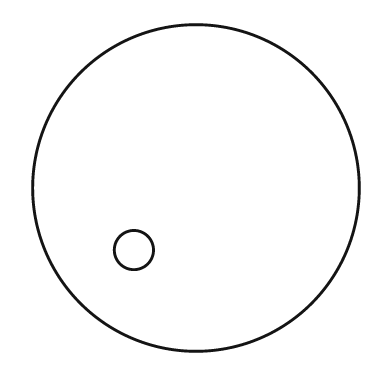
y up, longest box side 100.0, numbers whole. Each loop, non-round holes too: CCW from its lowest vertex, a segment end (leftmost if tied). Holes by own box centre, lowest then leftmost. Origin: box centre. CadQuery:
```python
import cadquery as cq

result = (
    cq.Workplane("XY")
    .moveTo(0.0, 0.0)
    .circle(50.0)
    .moveTo(-19.0, -19.0)
    .circle(6.0)
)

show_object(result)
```